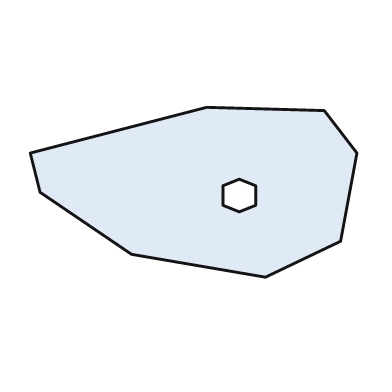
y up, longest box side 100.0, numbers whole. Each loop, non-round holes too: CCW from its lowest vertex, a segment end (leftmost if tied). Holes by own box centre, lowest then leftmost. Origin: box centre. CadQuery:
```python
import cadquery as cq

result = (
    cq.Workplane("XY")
    .moveTo(22.0, -26.0)
    .lineTo(45.0, -15.0)
    .lineTo(50.0, 12.0)
    .lineTo(40.0, 25.0)
    .lineTo(4.0, 26.0)
    .lineTo(-50.0, 12.0)
    .lineTo(-47.0, 0.0)
    .lineTo(-19.0, -19.0)
    .close()
    .moveTo(14.0, -6.0)
    .lineTo(19.0, -4.0)
    .lineTo(19.0, 2.0)
    .lineTo(14.0, 4.0)
    .lineTo(9.0, 2.0)
    .lineTo(9.0, -4.0)
    .close()
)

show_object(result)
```